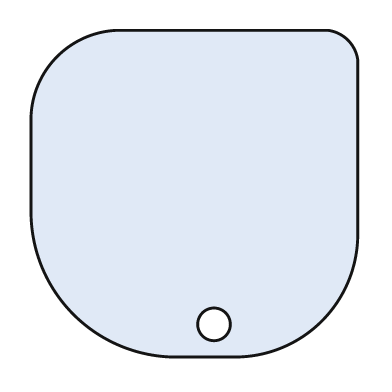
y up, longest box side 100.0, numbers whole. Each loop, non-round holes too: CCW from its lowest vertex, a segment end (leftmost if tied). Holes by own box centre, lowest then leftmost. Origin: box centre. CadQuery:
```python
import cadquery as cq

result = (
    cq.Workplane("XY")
    .moveTo(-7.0, -50.0)
    .lineTo(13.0, -50.0)
    .threePointArc((39.0, -39.0), (50.0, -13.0))
    .lineTo(50.0, 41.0)
    .threePointArc((47.0, 47.0), (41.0, 50.0))
    .lineTo(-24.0, 50.0)
    .threePointArc((-42.0, 42.0), (-50.0, 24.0))
    .lineTo(-50.0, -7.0)
    .threePointArc((-37.0, -37.0), (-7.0, -50.0))
    .close()
    .moveTo(6.0, -40.0)
    .circle(5.0)
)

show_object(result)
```